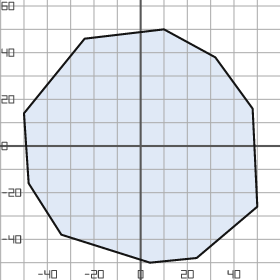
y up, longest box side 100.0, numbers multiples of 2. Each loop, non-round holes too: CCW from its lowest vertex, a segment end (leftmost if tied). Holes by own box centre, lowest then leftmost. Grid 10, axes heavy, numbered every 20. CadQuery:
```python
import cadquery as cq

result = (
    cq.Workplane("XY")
    .moveTo(4.0, -50.0)
    .lineTo(24.0, -48.0)
    .lineTo(50.0, -26.0)
    .lineTo(48.0, 16.0)
    .lineTo(32.0, 38.0)
    .lineTo(10.0, 50.0)
    .lineTo(-24.0, 46.0)
    .lineTo(-50.0, 14.0)
    .lineTo(-48.0, -16.0)
    .lineTo(-34.0, -38.0)
    .close()
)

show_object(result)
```